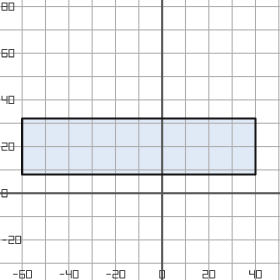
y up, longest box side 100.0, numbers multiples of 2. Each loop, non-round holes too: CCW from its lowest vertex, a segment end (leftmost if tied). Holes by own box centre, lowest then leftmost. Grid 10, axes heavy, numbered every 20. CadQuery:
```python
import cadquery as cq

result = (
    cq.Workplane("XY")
    .moveTo(-60.0, 8.0)
    .lineTo(40.0, 8.0)
    .lineTo(40.0, 32.0)
    .lineTo(-60.0, 32.0)
    .close()
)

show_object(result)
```